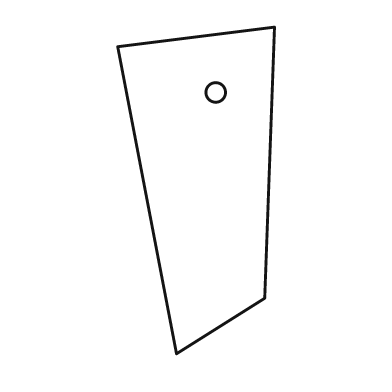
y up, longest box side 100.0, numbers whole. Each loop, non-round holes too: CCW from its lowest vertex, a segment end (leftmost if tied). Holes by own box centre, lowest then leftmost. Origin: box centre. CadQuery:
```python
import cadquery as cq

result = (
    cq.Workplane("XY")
    .moveTo(-6.0, -50.0)
    .lineTo(21.0, -33.0)
    .lineTo(24.0, 50.0)
    .lineTo(-24.0, 44.0)
    .close()
    .moveTo(6.0, 30.0)
    .circle(3.0)
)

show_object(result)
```